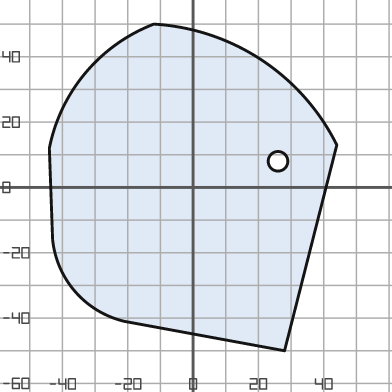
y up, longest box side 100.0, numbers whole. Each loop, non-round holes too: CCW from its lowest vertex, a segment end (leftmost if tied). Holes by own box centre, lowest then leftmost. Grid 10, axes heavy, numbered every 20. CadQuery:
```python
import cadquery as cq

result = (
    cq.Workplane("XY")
    .moveTo(28.0, -50.0)
    .lineTo(44.0, 13.0)
    .threePointArc((21.0, 39.0), (-12.0, 50.0))
    .threePointArc((-33.0, 35.0), (-44.0, 12.0))
    .lineTo(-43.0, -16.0)
    .threePointArc((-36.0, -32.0), (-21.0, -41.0))
    .close()
    .moveTo(26.0, 8.0)
    .circle(3.0)
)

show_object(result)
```